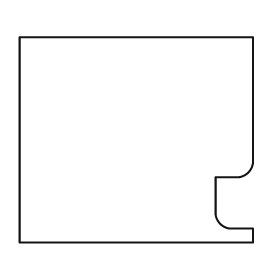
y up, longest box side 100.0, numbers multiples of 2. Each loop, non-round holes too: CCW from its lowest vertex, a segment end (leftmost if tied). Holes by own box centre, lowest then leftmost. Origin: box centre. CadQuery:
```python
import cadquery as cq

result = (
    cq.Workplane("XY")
    .moveTo(-50.0, -44.0)
    .lineTo(50.0, -44.0)
    .lineTo(50.0, -38.0)
    .lineTo(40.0, -38.0)
    .threePointArc((36.0, -36.0), (34.0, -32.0))
    .lineTo(34.0, -16.0)
    .lineTo(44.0, -16.0)
    .threePointArc((48.0, -14.0), (50.0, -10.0))
    .lineTo(50.0, 44.0)
    .lineTo(-50.0, 44.0)
    .close()
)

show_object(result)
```